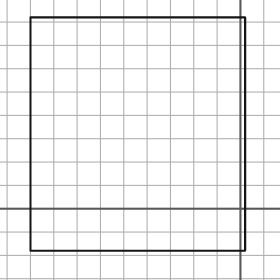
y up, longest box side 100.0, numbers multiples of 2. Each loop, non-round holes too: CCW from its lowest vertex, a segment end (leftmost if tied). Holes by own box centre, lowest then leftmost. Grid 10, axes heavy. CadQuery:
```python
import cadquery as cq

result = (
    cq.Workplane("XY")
    .moveTo(-90.0, -18.0)
    .lineTo(2.0, -18.0)
    .lineTo(2.0, 82.0)
    .lineTo(-90.0, 82.0)
    .close()
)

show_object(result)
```